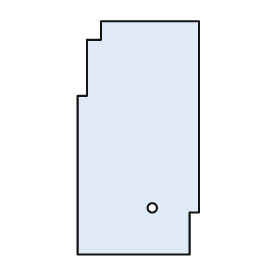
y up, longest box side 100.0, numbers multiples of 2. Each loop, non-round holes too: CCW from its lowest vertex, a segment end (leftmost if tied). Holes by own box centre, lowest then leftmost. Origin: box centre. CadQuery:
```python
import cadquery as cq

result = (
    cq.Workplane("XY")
    .moveTo(-26.0, -50.0)
    .lineTo(22.0, -50.0)
    .lineTo(22.0, -32.0)
    .lineTo(26.0, -32.0)
    .lineTo(26.0, 50.0)
    .lineTo(-16.0, 50.0)
    .lineTo(-16.0, 42.0)
    .lineTo(-22.0, 42.0)
    .lineTo(-22.0, 18.0)
    .lineTo(-26.0, 18.0)
    .close()
    .moveTo(6.0, -30.0)
    .circle(2.0)
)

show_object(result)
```